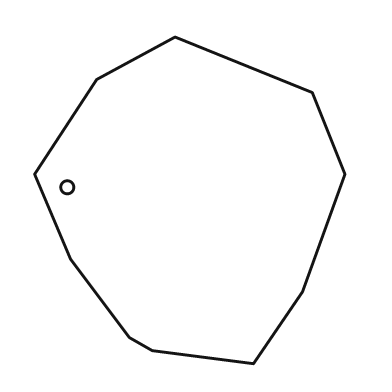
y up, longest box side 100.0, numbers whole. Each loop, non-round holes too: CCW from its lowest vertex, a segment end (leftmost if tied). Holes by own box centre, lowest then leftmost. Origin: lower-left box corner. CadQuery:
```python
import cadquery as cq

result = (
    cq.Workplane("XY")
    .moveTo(67.0, 0.0)
    .lineTo(82.0, 22.0)
    .lineTo(95.0, 58.0)
    .lineTo(85.0, 83.0)
    .lineTo(43.0, 100.0)
    .lineTo(19.0, 87.0)
    .lineTo(0.0, 58.0)
    .lineTo(11.0, 32.0)
    .lineTo(29.0, 8.0)
    .lineTo(36.0, 4.0)
    .close()
    .moveTo(10.0, 54.0)
    .circle(2.0)
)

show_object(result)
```